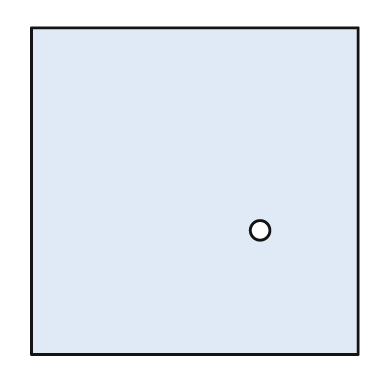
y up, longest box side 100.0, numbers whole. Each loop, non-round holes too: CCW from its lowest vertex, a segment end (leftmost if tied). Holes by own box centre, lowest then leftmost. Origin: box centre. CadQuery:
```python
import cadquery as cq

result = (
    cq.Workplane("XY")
    .moveTo(-50.0, -50.0)
    .lineTo(50.0, -50.0)
    .lineTo(50.0, 50.0)
    .lineTo(-50.0, 50.0)
    .close()
    .moveTo(20.0, -12.0)
    .circle(3.0)
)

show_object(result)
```